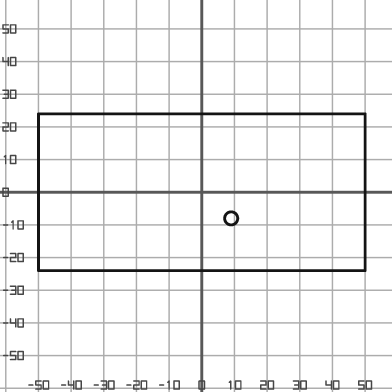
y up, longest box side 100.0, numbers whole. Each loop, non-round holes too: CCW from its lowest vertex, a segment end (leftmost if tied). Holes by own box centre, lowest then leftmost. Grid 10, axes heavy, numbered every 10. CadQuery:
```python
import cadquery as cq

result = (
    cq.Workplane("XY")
    .moveTo(-50.0, -24.0)
    .lineTo(50.0, -24.0)
    .lineTo(50.0, 24.0)
    .lineTo(-50.0, 24.0)
    .close()
    .moveTo(9.0, -8.0)
    .circle(2.0)
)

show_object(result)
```